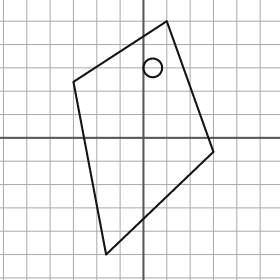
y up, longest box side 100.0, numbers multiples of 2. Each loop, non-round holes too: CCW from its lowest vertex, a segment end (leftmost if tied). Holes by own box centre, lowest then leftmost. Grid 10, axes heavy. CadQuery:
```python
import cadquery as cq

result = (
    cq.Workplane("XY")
    .moveTo(-16.0, -50.0)
    .lineTo(30.0, -6.0)
    .lineTo(10.0, 50.0)
    .lineTo(-30.0, 24.0)
    .close()
    .moveTo(4.0, 30.0)
    .circle(4.0)
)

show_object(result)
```